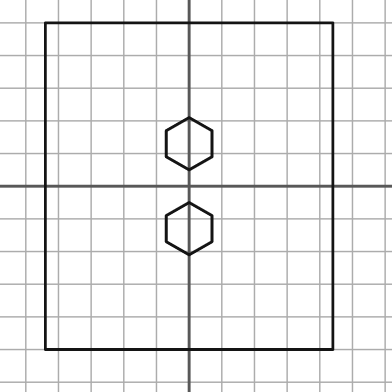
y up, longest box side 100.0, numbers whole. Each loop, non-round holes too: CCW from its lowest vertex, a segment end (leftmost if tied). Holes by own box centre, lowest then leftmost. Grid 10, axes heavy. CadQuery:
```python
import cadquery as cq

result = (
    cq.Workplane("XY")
    .moveTo(-44.0, -50.0)
    .lineTo(44.0, -50.0)
    .lineTo(44.0, 50.0)
    .lineTo(-44.0, 50.0)
    .close()
    .moveTo(0.0, -21.0)
    .lineTo(7.0, -17.0)
    .lineTo(7.0, -9.0)
    .lineTo(0.0, -5.0)
    .lineTo(-7.0, -9.0)
    .lineTo(-7.0, -17.0)
    .close()
    .moveTo(0.0, 5.0)
    .lineTo(7.0, 9.0)
    .lineTo(7.0, 17.0)
    .lineTo(0.0, 21.0)
    .lineTo(-7.0, 17.0)
    .lineTo(-7.0, 9.0)
    .close()
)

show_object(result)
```